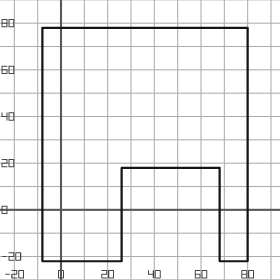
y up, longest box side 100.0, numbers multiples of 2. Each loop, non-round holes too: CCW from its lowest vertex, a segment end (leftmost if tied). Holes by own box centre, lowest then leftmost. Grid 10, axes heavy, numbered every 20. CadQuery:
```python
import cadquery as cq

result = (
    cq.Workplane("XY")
    .moveTo(-8.0, -22.0)
    .lineTo(26.0, -22.0)
    .lineTo(26.0, 18.0)
    .lineTo(68.0, 18.0)
    .lineTo(68.0, -22.0)
    .lineTo(80.0, -22.0)
    .lineTo(80.0, 78.0)
    .lineTo(-8.0, 78.0)
    .close()
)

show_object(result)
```